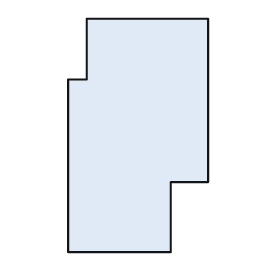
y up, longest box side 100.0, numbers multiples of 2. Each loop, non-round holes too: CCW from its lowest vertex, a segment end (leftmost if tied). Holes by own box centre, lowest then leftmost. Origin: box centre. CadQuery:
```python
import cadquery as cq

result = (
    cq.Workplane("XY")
    .moveTo(-30.0, -50.0)
    .lineTo(14.0, -50.0)
    .lineTo(14.0, -20.0)
    .lineTo(30.0, -20.0)
    .lineTo(30.0, 50.0)
    .lineTo(-22.0, 50.0)
    .lineTo(-22.0, 24.0)
    .lineTo(-30.0, 24.0)
    .close()
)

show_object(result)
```